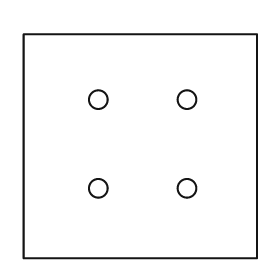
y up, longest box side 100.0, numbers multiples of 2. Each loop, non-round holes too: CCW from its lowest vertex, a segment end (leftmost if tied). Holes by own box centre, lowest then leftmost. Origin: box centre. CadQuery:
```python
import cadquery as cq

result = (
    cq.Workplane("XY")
    .moveTo(-50.0, -48.0)
    .lineTo(50.0, -48.0)
    .lineTo(50.0, 48.0)
    .lineTo(-50.0, 48.0)
    .close()
    .moveTo(-18.0, -18.0)
    .circle(4.0)
    .moveTo(20.0, -18.0)
    .circle(4.0)
    .moveTo(-18.0, 20.0)
    .circle(4.0)
    .moveTo(20.0, 20.0)
    .circle(4.0)
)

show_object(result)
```